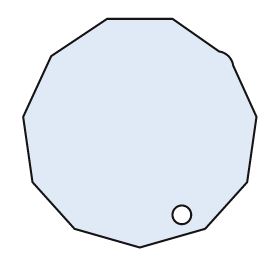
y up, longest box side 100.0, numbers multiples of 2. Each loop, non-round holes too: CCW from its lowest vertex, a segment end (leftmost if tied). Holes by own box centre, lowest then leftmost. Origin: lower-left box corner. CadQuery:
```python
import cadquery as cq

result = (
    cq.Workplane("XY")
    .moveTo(50.0, 0.0)
    .lineTo(78.0, 8.0)
    .lineTo(96.0, 28.0)
    .lineTo(100.0, 56.0)
    .lineTo(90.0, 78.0)
    .threePointArc((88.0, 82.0), (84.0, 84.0))
    .lineTo(64.0, 98.0)
    .lineTo(36.0, 98.0)
    .lineTo(12.0, 82.0)
    .lineTo(0.0, 56.0)
    .lineTo(4.0, 28.0)
    .lineTo(22.0, 8.0)
    .close()
    .moveTo(68.0, 14.0)
    .circle(4.0)
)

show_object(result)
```